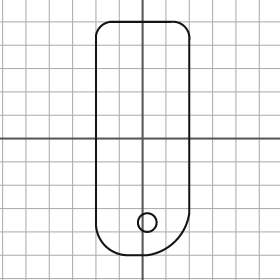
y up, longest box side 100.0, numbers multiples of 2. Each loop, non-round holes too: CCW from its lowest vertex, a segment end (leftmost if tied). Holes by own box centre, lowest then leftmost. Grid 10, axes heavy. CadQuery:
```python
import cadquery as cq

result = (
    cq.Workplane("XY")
    .moveTo(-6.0, -50.0)
    .lineTo(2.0, -50.0)
    .threePointArc((14.0, -44.0), (20.0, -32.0))
    .lineTo(20.0, 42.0)
    .threePointArc((18.0, 48.0), (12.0, 50.0))
    .lineTo(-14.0, 50.0)
    .threePointArc((-18.0, 48.0), (-20.0, 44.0))
    .lineTo(-20.0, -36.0)
    .threePointArc((-16.0, -46.0), (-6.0, -50.0))
    .close()
    .moveTo(2.0, -36.0)
    .circle(4.0)
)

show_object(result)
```